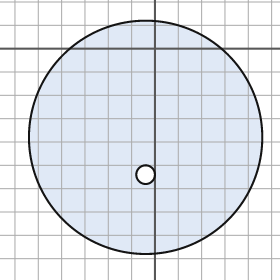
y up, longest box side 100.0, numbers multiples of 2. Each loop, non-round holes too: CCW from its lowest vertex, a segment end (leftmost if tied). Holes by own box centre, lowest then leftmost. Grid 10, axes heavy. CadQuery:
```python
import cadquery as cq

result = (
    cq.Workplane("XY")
    .moveTo(-4.0, -38.0)
    .circle(50.0)
    .moveTo(-4.0, -54.0)
    .circle(4.0)
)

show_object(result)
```